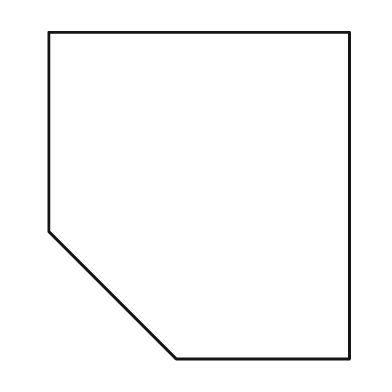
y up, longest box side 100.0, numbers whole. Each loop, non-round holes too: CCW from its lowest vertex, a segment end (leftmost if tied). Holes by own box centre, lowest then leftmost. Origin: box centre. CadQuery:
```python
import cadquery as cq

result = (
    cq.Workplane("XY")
    .moveTo(-7.0, -50.0)
    .lineTo(46.0, -50.0)
    .lineTo(46.0, 50.0)
    .lineTo(-46.0, 50.0)
    .lineTo(-46.0, -11.0)
    .close()
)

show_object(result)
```